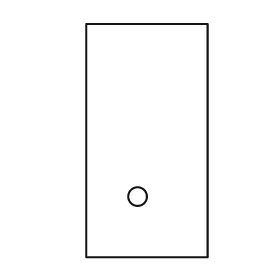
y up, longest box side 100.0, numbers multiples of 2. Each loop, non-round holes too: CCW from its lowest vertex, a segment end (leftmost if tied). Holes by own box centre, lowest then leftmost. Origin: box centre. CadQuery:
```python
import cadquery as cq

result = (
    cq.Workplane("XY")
    .moveTo(-26.0, -50.0)
    .lineTo(26.0, -50.0)
    .lineTo(26.0, 50.0)
    .lineTo(-26.0, 50.0)
    .close()
    .moveTo(-4.0, -24.0)
    .circle(4.0)
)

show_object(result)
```